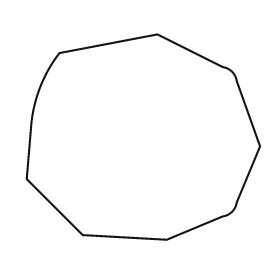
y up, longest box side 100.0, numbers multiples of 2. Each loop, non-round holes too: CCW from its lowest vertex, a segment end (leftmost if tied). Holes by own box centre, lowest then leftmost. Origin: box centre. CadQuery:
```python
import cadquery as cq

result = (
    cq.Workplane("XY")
    .moveTo(10.0, -44.0)
    .lineTo(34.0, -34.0)
    .threePointArc((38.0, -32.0), (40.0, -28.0))
    .lineTo(50.0, -4.0)
    .lineTo(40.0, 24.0)
    .threePointArc((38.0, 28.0), (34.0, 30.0))
    .lineTo(6.0, 44.0)
    .lineTo(-36.0, 36.0)
    .threePointArc((-44.0, 22.0), (-48.0, 6.0))
    .lineTo(-50.0, -18.0)
    .lineTo(-26.0, -42.0)
    .close()
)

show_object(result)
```